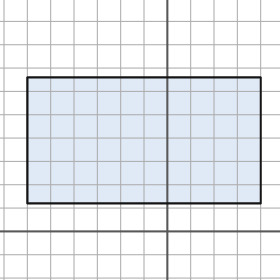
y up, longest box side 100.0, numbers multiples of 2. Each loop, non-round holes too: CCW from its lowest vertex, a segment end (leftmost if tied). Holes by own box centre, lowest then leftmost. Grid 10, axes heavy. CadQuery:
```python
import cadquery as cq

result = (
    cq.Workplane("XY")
    .moveTo(-60.0, 12.0)
    .lineTo(40.0, 12.0)
    .lineTo(40.0, 66.0)
    .lineTo(-60.0, 66.0)
    .close()
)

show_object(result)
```